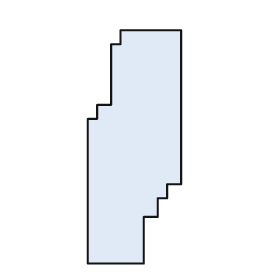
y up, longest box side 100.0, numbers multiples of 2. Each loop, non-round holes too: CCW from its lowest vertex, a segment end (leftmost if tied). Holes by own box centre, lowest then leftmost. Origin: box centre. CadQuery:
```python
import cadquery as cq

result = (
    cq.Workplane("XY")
    .moveTo(-20.0, -50.0)
    .lineTo(4.0, -50.0)
    .lineTo(4.0, -30.0)
    .lineTo(10.0, -30.0)
    .lineTo(10.0, -22.0)
    .lineTo(14.0, -22.0)
    .lineTo(14.0, -16.0)
    .lineTo(20.0, -16.0)
    .lineTo(20.0, 50.0)
    .lineTo(-6.0, 50.0)
    .lineTo(-6.0, 44.0)
    .lineTo(-10.0, 44.0)
    .lineTo(-10.0, 18.0)
    .lineTo(-16.0, 18.0)
    .lineTo(-16.0, 12.0)
    .lineTo(-20.0, 12.0)
    .close()
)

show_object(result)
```